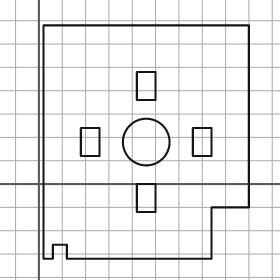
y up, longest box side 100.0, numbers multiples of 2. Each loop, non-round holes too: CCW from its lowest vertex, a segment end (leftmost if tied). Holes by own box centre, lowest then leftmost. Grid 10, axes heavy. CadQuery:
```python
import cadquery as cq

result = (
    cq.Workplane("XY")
    .moveTo(2.0, -32.0)
    .lineTo(6.0, -32.0)
    .lineTo(6.0, -26.0)
    .lineTo(12.0, -26.0)
    .lineTo(12.0, -32.0)
    .lineTo(74.0, -32.0)
    .lineTo(74.0, -10.0)
    .lineTo(90.0, -10.0)
    .lineTo(90.0, 68.0)
    .lineTo(2.0, 68.0)
    .close()
    .moveTo(42.0, -12.0)
    .lineTo(50.0, -12.0)
    .lineTo(50.0, 0.0)
    .lineTo(42.0, 0.0)
    .close()
    .moveTo(18.0, 12.0)
    .lineTo(26.0, 12.0)
    .lineTo(26.0, 24.0)
    .lineTo(18.0, 24.0)
    .close()
    .moveTo(46.0, 18.0)
    .circle(10.0)
    .moveTo(66.0, 12.0)
    .lineTo(74.0, 12.0)
    .lineTo(74.0, 24.0)
    .lineTo(66.0, 24.0)
    .close()
    .moveTo(42.0, 36.0)
    .lineTo(50.0, 36.0)
    .lineTo(50.0, 48.0)
    .lineTo(42.0, 48.0)
    .close()
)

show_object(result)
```